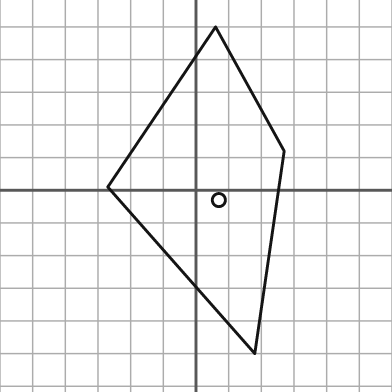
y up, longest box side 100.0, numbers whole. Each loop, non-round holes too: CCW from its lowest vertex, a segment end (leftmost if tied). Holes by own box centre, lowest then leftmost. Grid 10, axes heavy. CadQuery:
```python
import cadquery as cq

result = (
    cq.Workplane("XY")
    .moveTo(18.0, -50.0)
    .lineTo(27.0, 12.0)
    .lineTo(6.0, 50.0)
    .lineTo(-27.0, 1.0)
    .close()
    .moveTo(7.0, -3.0)
    .circle(2.0)
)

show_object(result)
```